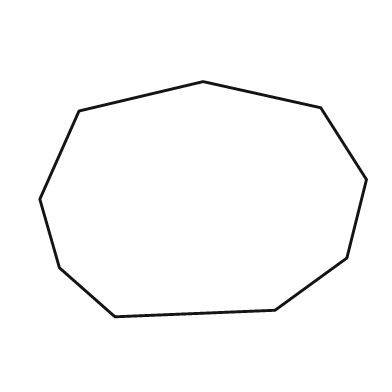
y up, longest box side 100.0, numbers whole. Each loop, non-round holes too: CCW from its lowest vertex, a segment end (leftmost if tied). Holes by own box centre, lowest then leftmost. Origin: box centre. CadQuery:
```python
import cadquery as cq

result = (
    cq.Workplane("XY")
    .moveTo(-27.0, -36.0)
    .lineTo(22.0, -34.0)
    .lineTo(44.0, -18.0)
    .lineTo(50.0, 6.0)
    .lineTo(36.0, 28.0)
    .lineTo(0.0, 36.0)
    .lineTo(-38.0, 27.0)
    .lineTo(-50.0, 0.0)
    .lineTo(-44.0, -21.0)
    .close()
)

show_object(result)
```